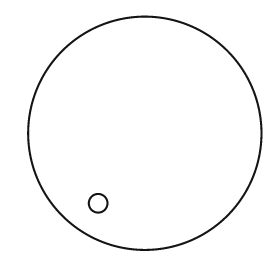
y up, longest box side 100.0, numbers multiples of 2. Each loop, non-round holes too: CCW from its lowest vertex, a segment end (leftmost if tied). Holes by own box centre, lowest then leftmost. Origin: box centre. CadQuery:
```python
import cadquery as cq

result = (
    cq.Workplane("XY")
    .moveTo(0.0, 0.0)
    .circle(50.0)
    .moveTo(-20.0, -30.0)
    .circle(4.0)
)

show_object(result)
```